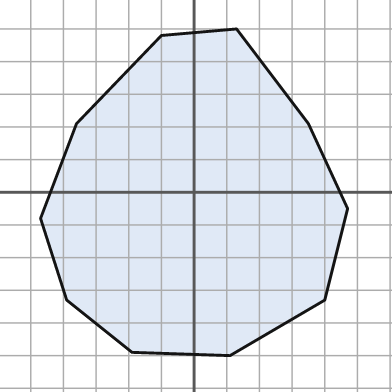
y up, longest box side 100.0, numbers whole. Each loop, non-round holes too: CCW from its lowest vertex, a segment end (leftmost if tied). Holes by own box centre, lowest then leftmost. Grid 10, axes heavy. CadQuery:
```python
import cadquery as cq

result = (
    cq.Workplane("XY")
    .moveTo(11.0, -50.0)
    .lineTo(40.0, -33.0)
    .lineTo(47.0, -5.0)
    .lineTo(35.0, 21.0)
    .lineTo(13.0, 50.0)
    .lineTo(-10.0, 48.0)
    .lineTo(-36.0, 21.0)
    .lineTo(-47.0, -8.0)
    .lineTo(-39.0, -33.0)
    .lineTo(-19.0, -49.0)
    .close()
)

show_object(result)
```